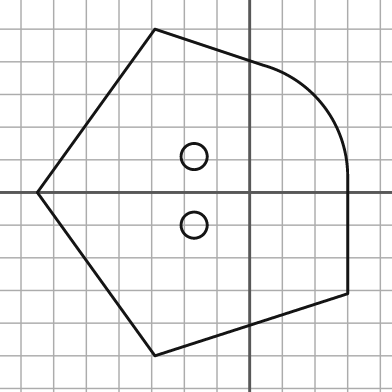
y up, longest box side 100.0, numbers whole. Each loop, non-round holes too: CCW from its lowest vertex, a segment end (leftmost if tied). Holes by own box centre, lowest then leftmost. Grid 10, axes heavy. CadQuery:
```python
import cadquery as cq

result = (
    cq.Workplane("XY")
    .moveTo(-29.0, -50.0)
    .lineTo(30.0, -31.0)
    .lineTo(30.0, 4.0)
    .threePointArc((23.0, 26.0), (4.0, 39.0))
    .lineTo(-29.0, 50.0)
    .lineTo(-65.0, 0.0)
    .close()
    .moveTo(-17.0, -10.0)
    .circle(4.0)
    .moveTo(-17.0, 11.0)
    .circle(4.0)
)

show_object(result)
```